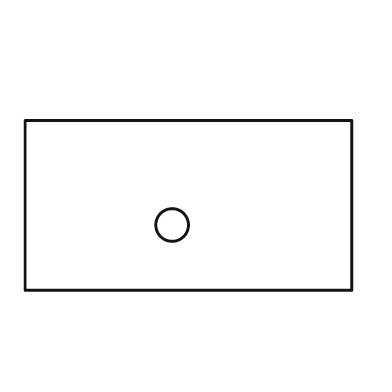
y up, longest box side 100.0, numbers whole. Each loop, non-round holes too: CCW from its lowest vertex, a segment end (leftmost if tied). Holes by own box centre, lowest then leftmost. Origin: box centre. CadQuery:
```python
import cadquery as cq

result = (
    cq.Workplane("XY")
    .moveTo(-50.0, -26.0)
    .lineTo(50.0, -26.0)
    .lineTo(50.0, 26.0)
    .lineTo(-50.0, 26.0)
    .close()
    .moveTo(-5.0, -6.0)
    .circle(5.0)
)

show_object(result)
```